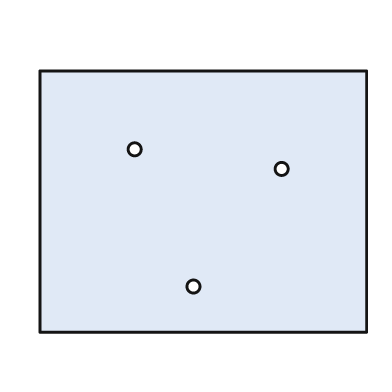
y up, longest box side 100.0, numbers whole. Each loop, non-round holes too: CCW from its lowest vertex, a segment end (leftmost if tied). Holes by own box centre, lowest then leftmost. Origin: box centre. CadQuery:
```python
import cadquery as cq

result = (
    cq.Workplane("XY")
    .moveTo(-50.0, -40.0)
    .lineTo(50.0, -40.0)
    .lineTo(50.0, 40.0)
    .lineTo(-50.0, 40.0)
    .close()
    .moveTo(-3.0, -26.0)
    .circle(2.0)
    .moveTo(24.0, 10.0)
    .circle(2.0)
    .moveTo(-21.0, 16.0)
    .circle(2.0)
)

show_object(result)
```